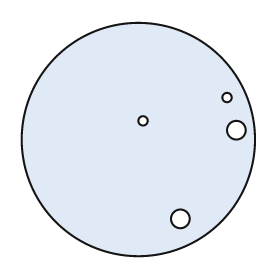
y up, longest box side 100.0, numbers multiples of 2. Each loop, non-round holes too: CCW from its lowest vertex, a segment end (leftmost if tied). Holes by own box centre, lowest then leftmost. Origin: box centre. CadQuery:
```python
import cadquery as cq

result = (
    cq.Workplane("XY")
    .moveTo(0.0, 0.0)
    .circle(50.0)
    .moveTo(18.0, -34.0)
    .circle(4.0)
    .moveTo(42.0, 4.0)
    .circle(4.0)
    .moveTo(2.0, 8.0)
    .circle(2.0)
    .moveTo(38.0, 18.0)
    .circle(2.0)
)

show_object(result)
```